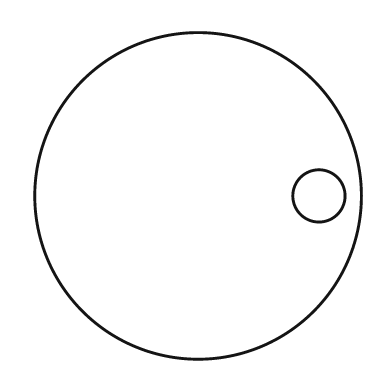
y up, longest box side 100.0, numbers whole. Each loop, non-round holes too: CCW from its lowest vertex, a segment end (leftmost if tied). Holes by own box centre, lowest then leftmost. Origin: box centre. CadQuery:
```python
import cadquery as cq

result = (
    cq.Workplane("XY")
    .moveTo(0.0, 0.0)
    .circle(50.0)
    .moveTo(37.0, 0.0)
    .circle(8.0)
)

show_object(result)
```